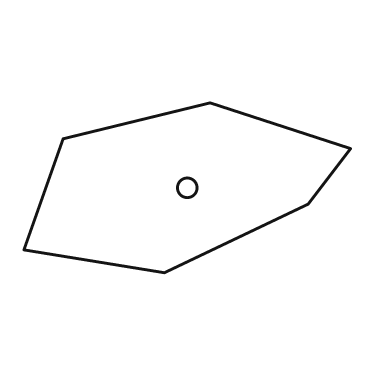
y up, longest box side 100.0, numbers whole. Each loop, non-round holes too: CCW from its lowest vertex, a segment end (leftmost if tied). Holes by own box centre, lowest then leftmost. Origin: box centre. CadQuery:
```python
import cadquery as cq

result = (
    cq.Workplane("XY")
    .moveTo(-7.0, -26.0)
    .lineTo(37.0, -5.0)
    .lineTo(50.0, 12.0)
    .lineTo(7.0, 26.0)
    .lineTo(-38.0, 15.0)
    .lineTo(-50.0, -19.0)
    .close()
    .moveTo(0.0, 0.0)
    .circle(3.0)
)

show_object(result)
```